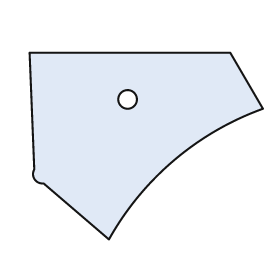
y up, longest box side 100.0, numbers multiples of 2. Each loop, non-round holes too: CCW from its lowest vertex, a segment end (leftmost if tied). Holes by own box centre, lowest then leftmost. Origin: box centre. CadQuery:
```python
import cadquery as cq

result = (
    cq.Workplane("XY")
    .moveTo(-16.0, -40.0)
    .threePointArc((12.0, -6.0), (50.0, 16.0))
    .lineTo(36.0, 40.0)
    .lineTo(-50.0, 40.0)
    .lineTo(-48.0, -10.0)
    .threePointArc((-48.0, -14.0), (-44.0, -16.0))
    .close()
    .moveTo(-8.0, 20.0)
    .circle(4.0)
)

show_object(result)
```